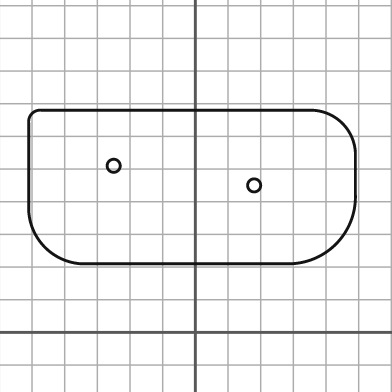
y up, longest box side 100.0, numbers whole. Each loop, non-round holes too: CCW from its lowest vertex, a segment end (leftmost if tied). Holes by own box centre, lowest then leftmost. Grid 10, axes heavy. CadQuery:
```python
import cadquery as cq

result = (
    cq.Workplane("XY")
    .moveTo(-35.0, 21.0)
    .lineTo(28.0, 21.0)
    .threePointArc((43.0, 27.0), (49.0, 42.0))
    .lineTo(49.0, 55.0)
    .threePointArc((45.0, 64.0), (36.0, 68.0))
    .lineTo(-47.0, 68.0)
    .threePointArc((-50.0, 67.0), (-51.0, 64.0))
    .lineTo(-51.0, 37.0)
    .threePointArc((-46.0, 26.0), (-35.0, 21.0))
    .close()
    .moveTo(18.0, 45.0)
    .circle(2.0)
    .moveTo(-25.0, 51.0)
    .circle(2.0)
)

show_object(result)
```